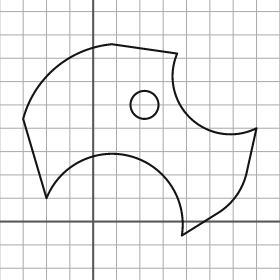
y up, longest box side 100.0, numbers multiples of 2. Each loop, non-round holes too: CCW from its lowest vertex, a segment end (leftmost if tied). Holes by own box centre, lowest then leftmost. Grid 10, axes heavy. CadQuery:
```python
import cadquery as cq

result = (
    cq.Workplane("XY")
    .moveTo(38.0, -6.0)
    .lineTo(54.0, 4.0)
    .threePointArc((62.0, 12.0), (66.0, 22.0))
    .lineTo(70.0, 40.0)
    .threePointArc((42.0, 44.0), (36.0, 72.0))
    .lineTo(8.0, 76.0)
    .threePointArc((-16.0, 66.0), (-30.0, 44.0))
    .lineTo(-20.0, 10.0)
    .threePointArc((16.0, 28.0), (38.0, -6.0))
    .close()
    .moveTo(22.0, 50.0)
    .circle(6.0)
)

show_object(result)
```